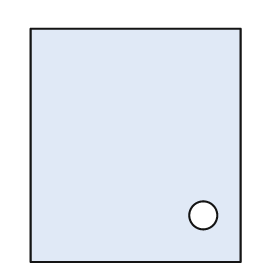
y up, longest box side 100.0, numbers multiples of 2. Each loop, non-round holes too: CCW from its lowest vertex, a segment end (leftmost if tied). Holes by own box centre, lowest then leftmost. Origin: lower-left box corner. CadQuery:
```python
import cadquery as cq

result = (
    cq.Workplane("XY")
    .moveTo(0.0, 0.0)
    .lineTo(90.0, 0.0)
    .lineTo(90.0, 100.0)
    .lineTo(0.0, 100.0)
    .close()
    .moveTo(74.0, 20.0)
    .circle(6.0)
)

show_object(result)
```